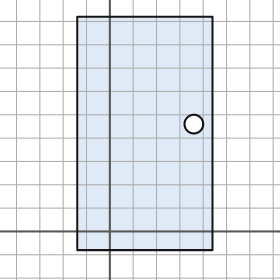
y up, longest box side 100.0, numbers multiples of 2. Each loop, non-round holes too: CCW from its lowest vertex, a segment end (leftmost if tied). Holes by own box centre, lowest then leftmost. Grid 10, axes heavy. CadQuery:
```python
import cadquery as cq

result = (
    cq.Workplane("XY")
    .moveTo(-14.0, -8.0)
    .lineTo(44.0, -8.0)
    .lineTo(44.0, 92.0)
    .lineTo(-14.0, 92.0)
    .close()
    .moveTo(36.0, 46.0)
    .circle(4.0)
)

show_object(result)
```